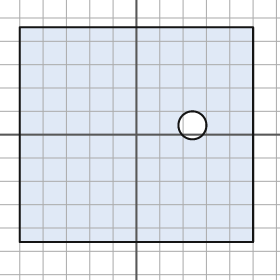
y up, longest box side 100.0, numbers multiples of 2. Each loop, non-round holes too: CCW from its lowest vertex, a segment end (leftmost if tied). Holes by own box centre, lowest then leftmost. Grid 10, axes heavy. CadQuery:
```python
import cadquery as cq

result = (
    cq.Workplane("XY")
    .moveTo(-50.0, -46.0)
    .lineTo(50.0, -46.0)
    .lineTo(50.0, 46.0)
    .lineTo(-50.0, 46.0)
    .close()
    .moveTo(24.0, 4.0)
    .circle(6.0)
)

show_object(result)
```